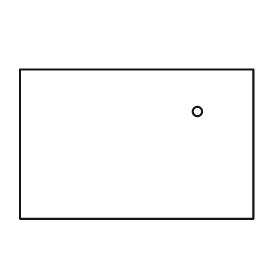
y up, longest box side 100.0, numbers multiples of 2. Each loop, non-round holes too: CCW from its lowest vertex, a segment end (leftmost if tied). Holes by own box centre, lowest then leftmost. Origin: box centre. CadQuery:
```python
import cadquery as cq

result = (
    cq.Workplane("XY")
    .moveTo(-50.0, -32.0)
    .lineTo(50.0, -32.0)
    .lineTo(50.0, 32.0)
    .lineTo(-50.0, 32.0)
    .close()
    .moveTo(26.0, 14.0)
    .circle(2.0)
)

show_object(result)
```